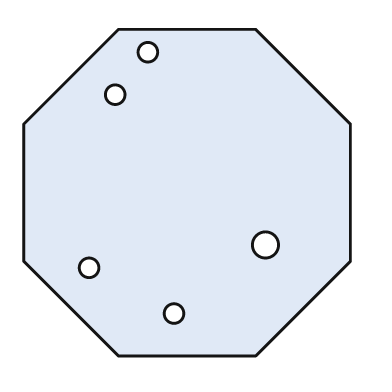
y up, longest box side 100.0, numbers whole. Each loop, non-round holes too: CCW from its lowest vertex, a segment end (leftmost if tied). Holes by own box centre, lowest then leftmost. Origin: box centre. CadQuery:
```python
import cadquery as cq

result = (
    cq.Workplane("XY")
    .moveTo(-21.0, -50.0)
    .lineTo(21.0, -50.0)
    .lineTo(50.0, -21.0)
    .lineTo(50.0, 21.0)
    .lineTo(21.0, 50.0)
    .lineTo(-21.0, 50.0)
    .lineTo(-50.0, 21.0)
    .lineTo(-50.0, -21.0)
    .close()
    .moveTo(-4.0, -37.0)
    .circle(3.0)
    .moveTo(-30.0, -23.0)
    .circle(3.0)
    .moveTo(24.0, -16.0)
    .circle(4.0)
    .moveTo(-22.0, 30.0)
    .circle(3.0)
    .moveTo(-12.0, 43.0)
    .circle(3.0)
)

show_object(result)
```